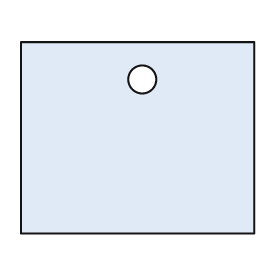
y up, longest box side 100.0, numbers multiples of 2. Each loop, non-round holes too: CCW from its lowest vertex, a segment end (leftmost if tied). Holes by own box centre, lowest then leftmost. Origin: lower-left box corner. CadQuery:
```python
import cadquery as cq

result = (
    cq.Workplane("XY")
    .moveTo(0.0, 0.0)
    .lineTo(100.0, 0.0)
    .lineTo(100.0, 82.0)
    .lineTo(0.0, 82.0)
    .close()
    .moveTo(52.0, 66.0)
    .circle(6.0)
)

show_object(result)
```